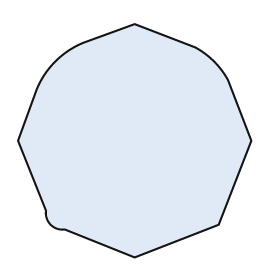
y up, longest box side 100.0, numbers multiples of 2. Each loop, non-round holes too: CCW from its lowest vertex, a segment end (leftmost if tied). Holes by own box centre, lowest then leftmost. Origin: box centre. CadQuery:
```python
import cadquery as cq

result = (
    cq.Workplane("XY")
    .moveTo(0.0, -50.0)
    .lineTo(36.0, -36.0)
    .lineTo(50.0, 0.0)
    .lineTo(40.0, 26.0)
    .threePointArc((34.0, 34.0), (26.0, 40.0))
    .lineTo(0.0, 50.0)
    .lineTo(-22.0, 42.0)
    .threePointArc((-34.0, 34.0), (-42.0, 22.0))
    .lineTo(-50.0, 0.0)
    .lineTo(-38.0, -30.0)
    .threePointArc((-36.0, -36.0), (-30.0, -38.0))
    .close()
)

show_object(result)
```